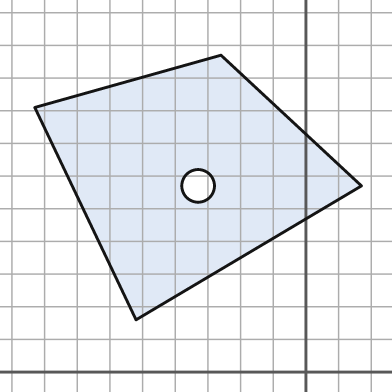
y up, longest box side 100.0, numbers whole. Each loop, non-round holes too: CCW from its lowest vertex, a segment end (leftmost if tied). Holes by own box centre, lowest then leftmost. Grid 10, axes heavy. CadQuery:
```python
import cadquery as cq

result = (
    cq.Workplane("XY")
    .moveTo(-52.0, 16.0)
    .lineTo(17.0, 57.0)
    .lineTo(-26.0, 97.0)
    .lineTo(-83.0, 81.0)
    .close()
    .moveTo(-33.0, 57.0)
    .circle(5.0)
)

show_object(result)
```